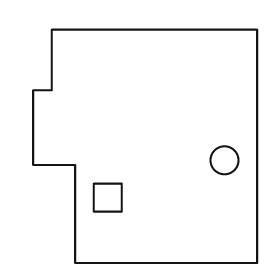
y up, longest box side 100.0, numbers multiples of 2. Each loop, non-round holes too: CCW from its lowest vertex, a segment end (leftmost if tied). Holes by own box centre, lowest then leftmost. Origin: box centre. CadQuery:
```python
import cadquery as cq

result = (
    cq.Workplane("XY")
    .moveTo(-30.0, -50.0)
    .lineTo(48.0, -50.0)
    .lineTo(48.0, 50.0)
    .lineTo(-40.0, 50.0)
    .lineTo(-40.0, 24.0)
    .lineTo(-48.0, 24.0)
    .lineTo(-48.0, -8.0)
    .lineTo(-30.0, -8.0)
    .close()
    .moveTo(-22.0, -28.0)
    .lineTo(-10.0, -28.0)
    .lineTo(-10.0, -16.0)
    .lineTo(-22.0, -16.0)
    .close()
    .moveTo(34.0, -6.0)
    .circle(6.0)
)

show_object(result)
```